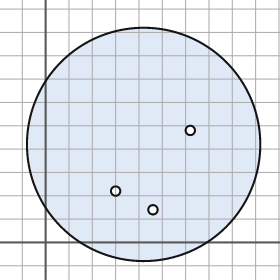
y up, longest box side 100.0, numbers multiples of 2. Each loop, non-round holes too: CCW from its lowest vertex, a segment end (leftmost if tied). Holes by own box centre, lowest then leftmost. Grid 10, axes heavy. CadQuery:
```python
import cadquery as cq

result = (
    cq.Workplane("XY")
    .moveTo(42.0, 42.0)
    .circle(50.0)
    .moveTo(46.0, 14.0)
    .circle(2.0)
    .moveTo(30.0, 22.0)
    .circle(2.0)
    .moveTo(62.0, 48.0)
    .circle(2.0)
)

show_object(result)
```